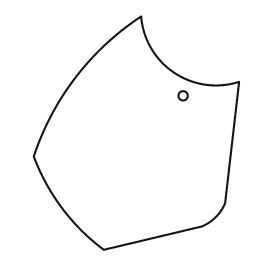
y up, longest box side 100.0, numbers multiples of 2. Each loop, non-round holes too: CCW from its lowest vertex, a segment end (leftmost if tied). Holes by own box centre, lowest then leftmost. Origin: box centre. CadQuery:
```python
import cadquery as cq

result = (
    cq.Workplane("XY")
    .moveTo(-14.0, -50.0)
    .lineTo(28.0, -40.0)
    .threePointArc((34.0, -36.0), (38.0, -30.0))
    .lineTo(44.0, 22.0)
    .threePointArc((16.0, 26.0), (2.0, 50.0))
    .threePointArc((-26.0, 24.0), (-44.0, -10.0))
    .threePointArc((-32.0, -32.0), (-14.0, -50.0))
    .close()
    .moveTo(20.0, 16.0)
    .circle(2.0)
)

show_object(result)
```